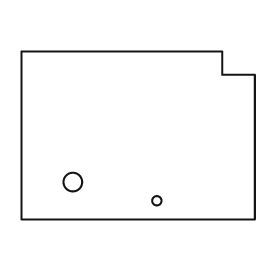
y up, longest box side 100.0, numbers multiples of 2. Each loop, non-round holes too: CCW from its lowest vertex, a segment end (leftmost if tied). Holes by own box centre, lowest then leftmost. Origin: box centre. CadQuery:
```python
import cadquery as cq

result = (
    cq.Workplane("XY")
    .moveTo(-50.0, -36.0)
    .lineTo(50.0, -36.0)
    .lineTo(50.0, 26.0)
    .lineTo(36.0, 26.0)
    .lineTo(36.0, 36.0)
    .lineTo(-50.0, 36.0)
    .close()
    .moveTo(8.0, -28.0)
    .circle(2.0)
    .moveTo(-28.0, -20.0)
    .circle(4.0)
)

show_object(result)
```